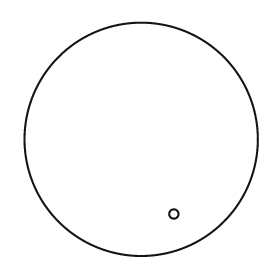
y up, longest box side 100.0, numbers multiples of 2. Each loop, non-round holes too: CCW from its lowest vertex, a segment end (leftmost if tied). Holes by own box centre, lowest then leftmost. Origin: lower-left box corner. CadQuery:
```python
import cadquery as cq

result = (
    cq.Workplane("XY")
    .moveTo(50.0, 50.0)
    .circle(50.0)
    .moveTo(64.0, 18.0)
    .circle(2.0)
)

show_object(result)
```